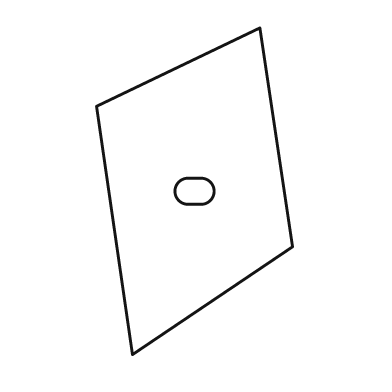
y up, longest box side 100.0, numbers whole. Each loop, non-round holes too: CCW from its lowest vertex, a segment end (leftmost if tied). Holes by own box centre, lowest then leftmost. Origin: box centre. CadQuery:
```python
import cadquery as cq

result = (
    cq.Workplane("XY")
    .moveTo(-19.0, -50.0)
    .lineTo(30.0, -17.0)
    .lineTo(20.0, 50.0)
    .lineTo(-30.0, 26.0)
    .close()
    .moveTo(-2.0, -4.0)
    .lineTo(2.0, -4.0)
    .threePointArc((6.0, 0.0), (2.0, 4.0))
    .lineTo(-2.0, 4.0)
    .threePointArc((-6.0, 0.0), (-2.0, -4.0))
    .close()
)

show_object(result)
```